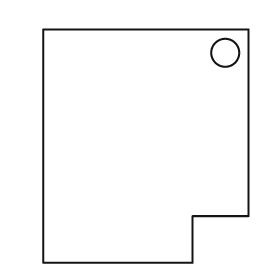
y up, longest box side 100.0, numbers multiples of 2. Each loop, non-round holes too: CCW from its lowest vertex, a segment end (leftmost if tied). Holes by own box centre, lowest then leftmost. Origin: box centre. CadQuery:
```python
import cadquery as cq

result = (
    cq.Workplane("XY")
    .moveTo(-44.0, -50.0)
    .lineTo(20.0, -50.0)
    .lineTo(20.0, -30.0)
    .lineTo(44.0, -30.0)
    .lineTo(44.0, 50.0)
    .lineTo(-44.0, 50.0)
    .close()
    .moveTo(34.0, 40.0)
    .circle(6.0)
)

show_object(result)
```